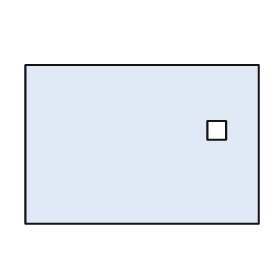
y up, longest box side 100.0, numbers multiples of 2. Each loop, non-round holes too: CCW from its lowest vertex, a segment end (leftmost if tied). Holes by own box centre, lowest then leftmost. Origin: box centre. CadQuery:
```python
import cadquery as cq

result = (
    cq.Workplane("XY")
    .moveTo(-50.0, -34.0)
    .lineTo(50.0, -34.0)
    .lineTo(50.0, 34.0)
    .lineTo(-50.0, 34.0)
    .close()
    .moveTo(28.0, 2.0)
    .lineTo(36.0, 2.0)
    .lineTo(36.0, 10.0)
    .lineTo(28.0, 10.0)
    .close()
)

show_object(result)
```